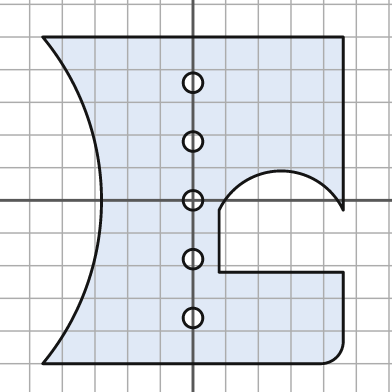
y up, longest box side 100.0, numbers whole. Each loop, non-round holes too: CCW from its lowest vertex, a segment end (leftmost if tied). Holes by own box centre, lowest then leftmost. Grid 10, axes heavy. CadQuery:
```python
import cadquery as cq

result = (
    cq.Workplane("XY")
    .moveTo(-46.0, -50.0)
    .lineTo(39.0, -50.0)
    .threePointArc((44.0, -48.0), (46.0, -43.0))
    .lineTo(46.0, -22.0)
    .lineTo(8.0, -22.0)
    .lineTo(8.0, -3.0)
    .threePointArc((27.0, 9.0), (46.0, -3.0))
    .lineTo(46.0, 50.0)
    .lineTo(-46.0, 50.0)
    .threePointArc((-28.0, 0.0), (-46.0, -50.0))
    .close()
    .moveTo(0.0, -36.0)
    .circle(3.0)
    .moveTo(0.0, -18.0)
    .circle(3.0)
    .moveTo(0.0, 0.0)
    .circle(3.0)
    .moveTo(0.0, 18.0)
    .circle(3.0)
    .moveTo(0.0, 36.0)
    .circle(3.0)
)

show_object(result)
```